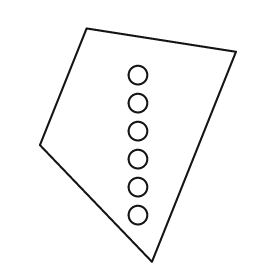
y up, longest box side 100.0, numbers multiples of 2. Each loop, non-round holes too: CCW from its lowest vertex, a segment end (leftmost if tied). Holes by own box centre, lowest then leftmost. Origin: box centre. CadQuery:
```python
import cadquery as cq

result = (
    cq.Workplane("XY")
    .moveTo(6.0, -50.0)
    .lineTo(42.0, 40.0)
    .lineTo(-22.0, 50.0)
    .lineTo(-42.0, 0.0)
    .close()
    .moveTo(0.0, -30.0)
    .circle(4.0)
    .moveTo(0.0, -18.0)
    .circle(4.0)
    .moveTo(0.0, -6.0)
    .circle(4.0)
    .moveTo(0.0, 6.0)
    .circle(4.0)
    .moveTo(0.0, 18.0)
    .circle(4.0)
    .moveTo(0.0, 30.0)
    .circle(4.0)
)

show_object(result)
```